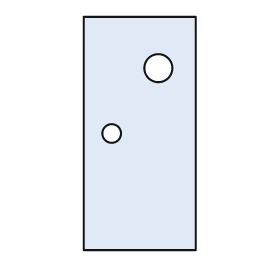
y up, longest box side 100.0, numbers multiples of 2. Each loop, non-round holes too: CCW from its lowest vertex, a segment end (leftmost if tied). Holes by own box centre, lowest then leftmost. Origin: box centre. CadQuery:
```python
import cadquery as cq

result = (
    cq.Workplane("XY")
    .moveTo(-24.0, -50.0)
    .lineTo(24.0, -50.0)
    .lineTo(24.0, 50.0)
    .lineTo(-24.0, 50.0)
    .close()
    .moveTo(-12.0, 0.0)
    .circle(4.0)
    .moveTo(8.0, 28.0)
    .circle(6.0)
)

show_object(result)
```